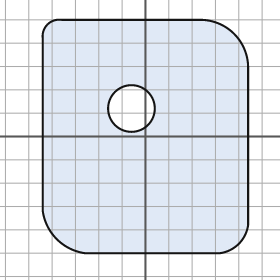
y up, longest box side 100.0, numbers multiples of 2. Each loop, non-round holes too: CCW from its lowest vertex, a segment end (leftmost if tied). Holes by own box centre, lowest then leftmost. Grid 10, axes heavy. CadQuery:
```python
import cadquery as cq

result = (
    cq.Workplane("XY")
    .moveTo(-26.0, -50.0)
    .lineTo(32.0, -50.0)
    .threePointArc((40.0, -46.0), (44.0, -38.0))
    .lineTo(44.0, 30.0)
    .threePointArc((38.0, 44.0), (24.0, 50.0))
    .lineTo(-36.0, 50.0)
    .threePointArc((-42.0, 48.0), (-44.0, 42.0))
    .lineTo(-44.0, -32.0)
    .threePointArc((-38.0, -44.0), (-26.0, -50.0))
    .close()
    .moveTo(-6.0, 12.0)
    .circle(10.0)
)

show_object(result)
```